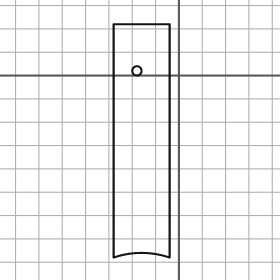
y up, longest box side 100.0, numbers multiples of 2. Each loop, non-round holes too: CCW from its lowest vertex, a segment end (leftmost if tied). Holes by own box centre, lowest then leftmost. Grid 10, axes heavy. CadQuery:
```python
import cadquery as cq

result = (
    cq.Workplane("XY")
    .moveTo(-28.0, -78.0)
    .threePointArc((-16.0, -76.0), (-4.0, -78.0))
    .lineTo(-4.0, 22.0)
    .lineTo(-28.0, 22.0)
    .close()
    .moveTo(-18.0, 2.0)
    .circle(2.0)
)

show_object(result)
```